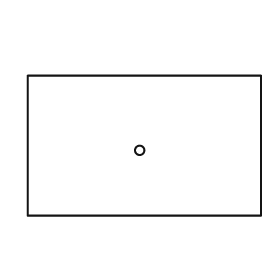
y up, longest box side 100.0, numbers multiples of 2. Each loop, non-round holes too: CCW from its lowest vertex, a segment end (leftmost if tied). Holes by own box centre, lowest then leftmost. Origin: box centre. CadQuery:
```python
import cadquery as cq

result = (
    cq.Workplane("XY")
    .moveTo(-50.0, -30.0)
    .lineTo(50.0, -30.0)
    .lineTo(50.0, 30.0)
    .lineTo(-50.0, 30.0)
    .close()
    .moveTo(-2.0, -2.0)
    .circle(2.0)
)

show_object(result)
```